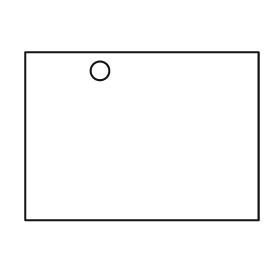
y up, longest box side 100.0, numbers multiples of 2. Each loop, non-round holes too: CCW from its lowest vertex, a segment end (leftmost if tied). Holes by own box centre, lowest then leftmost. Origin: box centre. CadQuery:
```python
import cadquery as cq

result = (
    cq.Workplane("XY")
    .moveTo(-50.0, -36.0)
    .lineTo(50.0, -36.0)
    .lineTo(50.0, 36.0)
    .lineTo(-50.0, 36.0)
    .close()
    .moveTo(-18.0, 28.0)
    .circle(4.0)
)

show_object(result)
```